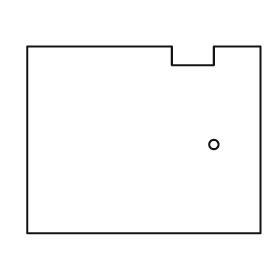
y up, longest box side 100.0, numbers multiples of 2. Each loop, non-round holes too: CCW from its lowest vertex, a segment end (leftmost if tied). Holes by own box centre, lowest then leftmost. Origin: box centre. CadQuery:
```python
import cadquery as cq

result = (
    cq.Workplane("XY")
    .moveTo(-50.0, -40.0)
    .lineTo(50.0, -40.0)
    .lineTo(50.0, 40.0)
    .lineTo(30.0, 40.0)
    .lineTo(30.0, 32.0)
    .lineTo(12.0, 32.0)
    .lineTo(12.0, 40.0)
    .lineTo(-50.0, 40.0)
    .close()
    .moveTo(30.0, -2.0)
    .circle(2.0)
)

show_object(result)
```